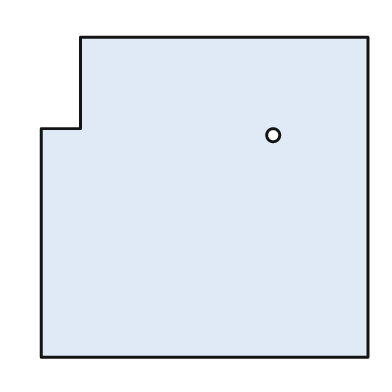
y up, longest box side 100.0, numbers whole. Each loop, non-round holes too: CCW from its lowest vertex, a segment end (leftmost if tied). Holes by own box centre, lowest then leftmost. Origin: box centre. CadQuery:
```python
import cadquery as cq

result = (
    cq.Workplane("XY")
    .moveTo(-50.0, -49.0)
    .lineTo(50.0, -49.0)
    .lineTo(50.0, 49.0)
    .lineTo(-38.0, 49.0)
    .lineTo(-38.0, 21.0)
    .lineTo(-50.0, 21.0)
    .close()
    .moveTo(21.0, 19.0)
    .circle(2.0)
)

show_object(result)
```